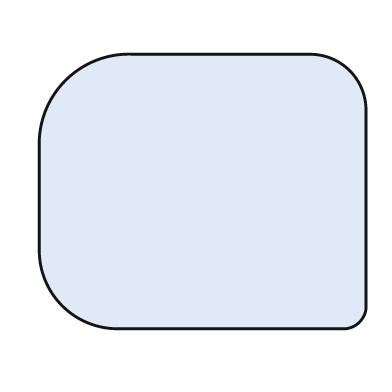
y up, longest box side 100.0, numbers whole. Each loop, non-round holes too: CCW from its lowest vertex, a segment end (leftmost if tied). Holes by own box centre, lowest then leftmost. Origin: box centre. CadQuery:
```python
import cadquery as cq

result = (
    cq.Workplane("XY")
    .moveTo(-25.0, -42.0)
    .lineTo(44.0, -42.0)
    .threePointArc((48.0, -40.0), (50.0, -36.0))
    .lineTo(50.0, 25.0)
    .threePointArc((45.0, 37.0), (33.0, 42.0))
    .lineTo(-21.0, 42.0)
    .threePointArc((-42.0, 34.0), (-50.0, 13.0))
    .lineTo(-50.0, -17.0)
    .threePointArc((-43.0, -35.0), (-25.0, -42.0))
    .close()
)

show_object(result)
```